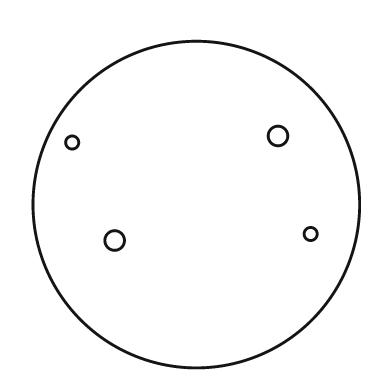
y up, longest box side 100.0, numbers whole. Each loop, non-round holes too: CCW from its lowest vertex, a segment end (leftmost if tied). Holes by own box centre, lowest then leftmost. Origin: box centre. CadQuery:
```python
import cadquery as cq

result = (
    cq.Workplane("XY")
    .moveTo(0.0, 0.0)
    .circle(50.0)
    .moveTo(-25.0, -11.0)
    .circle(3.0)
    .moveTo(35.0, -9.0)
    .circle(2.0)
    .moveTo(-38.0, 19.0)
    .circle(2.0)
    .moveTo(25.0, 21.0)
    .circle(3.0)
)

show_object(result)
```